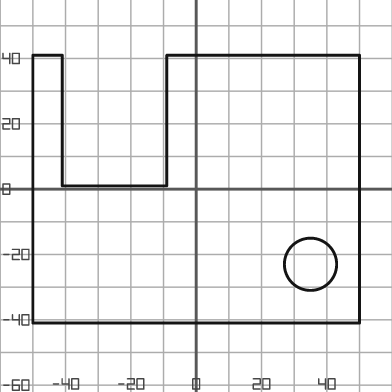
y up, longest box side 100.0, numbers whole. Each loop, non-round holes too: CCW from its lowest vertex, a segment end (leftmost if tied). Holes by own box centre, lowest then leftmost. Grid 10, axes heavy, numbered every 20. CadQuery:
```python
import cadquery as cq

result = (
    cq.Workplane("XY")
    .moveTo(-50.0, -41.0)
    .lineTo(50.0, -41.0)
    .lineTo(50.0, 41.0)
    .lineTo(-9.0, 41.0)
    .lineTo(-9.0, 1.0)
    .lineTo(-41.0, 1.0)
    .lineTo(-41.0, 41.0)
    .lineTo(-50.0, 41.0)
    .close()
    .moveTo(35.0, -23.0)
    .circle(8.0)
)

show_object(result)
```